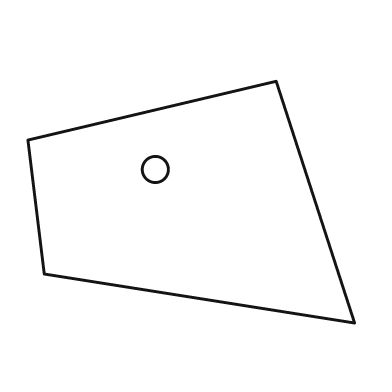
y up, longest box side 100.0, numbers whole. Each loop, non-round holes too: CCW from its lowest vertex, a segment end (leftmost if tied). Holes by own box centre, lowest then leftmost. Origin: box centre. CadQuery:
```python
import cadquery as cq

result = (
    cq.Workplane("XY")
    .moveTo(50.0, -37.0)
    .lineTo(26.0, 37.0)
    .lineTo(-50.0, 19.0)
    .lineTo(-45.0, -22.0)
    .close()
    .moveTo(-11.0, 10.0)
    .circle(4.0)
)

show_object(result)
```